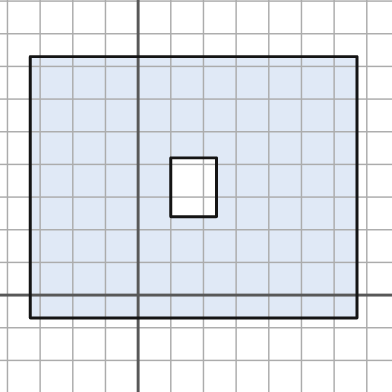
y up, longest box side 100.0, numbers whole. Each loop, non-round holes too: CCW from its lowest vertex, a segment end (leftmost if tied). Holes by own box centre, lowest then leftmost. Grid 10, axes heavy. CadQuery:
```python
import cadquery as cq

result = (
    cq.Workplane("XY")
    .moveTo(-33.0, -7.0)
    .lineTo(67.0, -7.0)
    .lineTo(67.0, 73.0)
    .lineTo(-33.0, 73.0)
    .close()
    .moveTo(10.0, 24.0)
    .lineTo(24.0, 24.0)
    .lineTo(24.0, 42.0)
    .lineTo(10.0, 42.0)
    .close()
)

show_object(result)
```